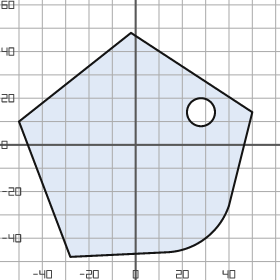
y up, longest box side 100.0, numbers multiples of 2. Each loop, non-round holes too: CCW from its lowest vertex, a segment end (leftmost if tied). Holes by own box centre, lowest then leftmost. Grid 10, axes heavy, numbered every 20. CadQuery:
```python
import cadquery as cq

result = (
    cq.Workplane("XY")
    .moveTo(-28.0, -48.0)
    .lineTo(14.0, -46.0)
    .threePointArc((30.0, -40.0), (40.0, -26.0))
    .lineTo(50.0, 14.0)
    .lineTo(-2.0, 48.0)
    .lineTo(-50.0, 10.0)
    .close()
    .moveTo(28.0, 14.0)
    .circle(6.0)
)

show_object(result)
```